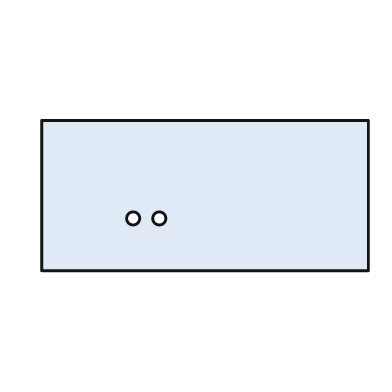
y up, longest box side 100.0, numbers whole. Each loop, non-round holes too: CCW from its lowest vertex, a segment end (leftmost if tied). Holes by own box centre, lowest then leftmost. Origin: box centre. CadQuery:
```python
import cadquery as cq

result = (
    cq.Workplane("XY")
    .moveTo(-50.0, -23.0)
    .lineTo(50.0, -23.0)
    .lineTo(50.0, 23.0)
    .lineTo(-50.0, 23.0)
    .close()
    .moveTo(-22.0, -7.0)
    .circle(2.0)
    .moveTo(-14.0, -7.0)
    .circle(2.0)
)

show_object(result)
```